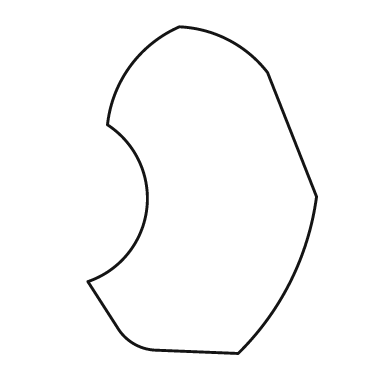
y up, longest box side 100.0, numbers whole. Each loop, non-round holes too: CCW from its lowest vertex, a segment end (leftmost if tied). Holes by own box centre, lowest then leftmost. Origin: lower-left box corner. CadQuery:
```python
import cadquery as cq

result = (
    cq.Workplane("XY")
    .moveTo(46.0, 0.0)
    .threePointArc((62.0, 22.0), (70.0, 48.0))
    .lineTo(55.0, 86.0)
    .threePointArc((43.0, 96.0), (28.0, 100.0))
    .threePointArc((13.0, 88.0), (6.0, 70.0))
    .threePointArc((18.0, 44.0), (0.0, 22.0))
    .lineTo(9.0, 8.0)
    .threePointArc((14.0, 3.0), (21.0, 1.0))
    .close()
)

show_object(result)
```